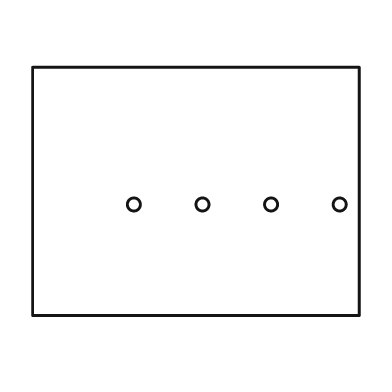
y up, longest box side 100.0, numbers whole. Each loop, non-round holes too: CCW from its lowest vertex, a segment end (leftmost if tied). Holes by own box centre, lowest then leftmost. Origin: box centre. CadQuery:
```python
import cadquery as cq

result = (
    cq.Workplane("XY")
    .moveTo(-50.0, -38.0)
    .lineTo(50.0, -38.0)
    .lineTo(50.0, 38.0)
    .lineTo(-50.0, 38.0)
    .close()
    .moveTo(-19.0, -4.0)
    .circle(2.0)
    .moveTo(2.0, -4.0)
    .circle(2.0)
    .moveTo(23.0, -4.0)
    .circle(2.0)
    .moveTo(44.0, -4.0)
    .circle(2.0)
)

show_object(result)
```